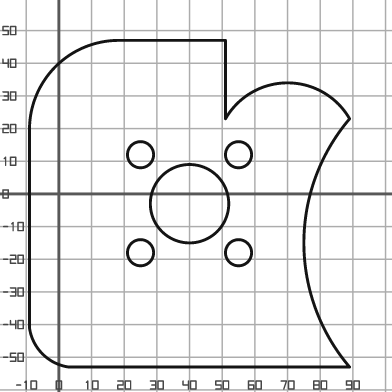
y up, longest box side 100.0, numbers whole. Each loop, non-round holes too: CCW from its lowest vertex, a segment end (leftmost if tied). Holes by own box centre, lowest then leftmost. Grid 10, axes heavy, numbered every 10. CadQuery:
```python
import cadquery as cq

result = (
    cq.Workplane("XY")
    .moveTo(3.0, -53.0)
    .lineTo(89.0, -53.0)
    .threePointArc((75.0, -15.0), (89.0, 23.0))
    .threePointArc((70.0, 34.0), (51.0, 23.0))
    .lineTo(51.0, 47.0)
    .lineTo(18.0, 47.0)
    .threePointArc((-1.0, 39.0), (-9.0, 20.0))
    .lineTo(-9.0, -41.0)
    .threePointArc((-5.0, -49.0), (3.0, -53.0))
    .close()
    .moveTo(25.0, -18.0)
    .circle(4.0)
    .moveTo(55.0, -18.0)
    .circle(4.0)
    .moveTo(40.0, -3.0)
    .circle(12.0)
    .moveTo(25.0, 12.0)
    .circle(4.0)
    .moveTo(55.0, 12.0)
    .circle(4.0)
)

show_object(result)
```